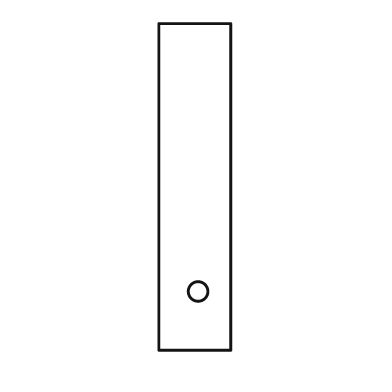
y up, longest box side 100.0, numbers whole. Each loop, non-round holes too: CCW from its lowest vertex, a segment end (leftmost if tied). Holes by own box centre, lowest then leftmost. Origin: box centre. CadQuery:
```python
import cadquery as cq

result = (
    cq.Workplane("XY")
    .moveTo(-11.0, -50.0)
    .lineTo(11.0, -50.0)
    .lineTo(11.0, 50.0)
    .lineTo(-11.0, 50.0)
    .close()
    .moveTo(1.0, -32.0)
    .circle(3.0)
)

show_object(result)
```